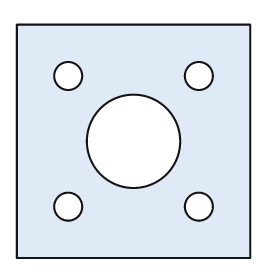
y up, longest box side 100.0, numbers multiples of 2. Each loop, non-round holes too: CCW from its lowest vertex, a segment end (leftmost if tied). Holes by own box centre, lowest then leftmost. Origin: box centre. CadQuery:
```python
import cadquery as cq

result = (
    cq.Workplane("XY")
    .moveTo(-50.0, -50.0)
    .lineTo(50.0, -50.0)
    .lineTo(50.0, 50.0)
    .lineTo(-50.0, 50.0)
    .close()
    .moveTo(-28.0, -28.0)
    .circle(6.0)
    .moveTo(28.0, -28.0)
    .circle(6.0)
    .moveTo(0.0, 0.0)
    .circle(20.0)
    .moveTo(-28.0, 28.0)
    .circle(6.0)
    .moveTo(28.0, 28.0)
    .circle(6.0)
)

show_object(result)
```